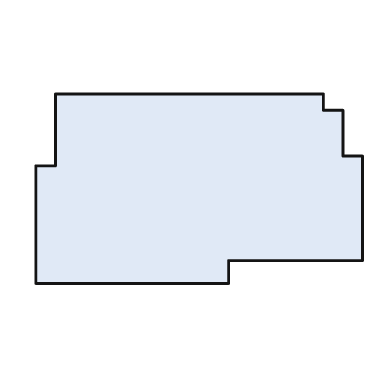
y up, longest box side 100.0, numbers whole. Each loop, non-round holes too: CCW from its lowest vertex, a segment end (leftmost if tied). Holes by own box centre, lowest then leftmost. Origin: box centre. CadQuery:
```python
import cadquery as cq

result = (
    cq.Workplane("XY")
    .moveTo(-50.0, -29.0)
    .lineTo(9.0, -29.0)
    .lineTo(9.0, -22.0)
    .lineTo(50.0, -22.0)
    .lineTo(50.0, 10.0)
    .lineTo(44.0, 10.0)
    .lineTo(44.0, 24.0)
    .lineTo(38.0, 24.0)
    .lineTo(38.0, 29.0)
    .lineTo(-44.0, 29.0)
    .lineTo(-44.0, 7.0)
    .lineTo(-50.0, 7.0)
    .close()
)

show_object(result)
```